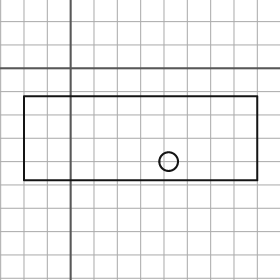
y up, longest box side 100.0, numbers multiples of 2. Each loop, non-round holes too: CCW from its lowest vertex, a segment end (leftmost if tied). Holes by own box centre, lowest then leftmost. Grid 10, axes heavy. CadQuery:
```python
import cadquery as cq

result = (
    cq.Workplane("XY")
    .moveTo(-20.0, -48.0)
    .lineTo(80.0, -48.0)
    .lineTo(80.0, -12.0)
    .lineTo(-20.0, -12.0)
    .close()
    .moveTo(42.0, -40.0)
    .circle(4.0)
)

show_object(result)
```